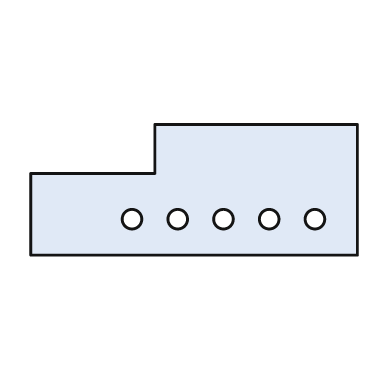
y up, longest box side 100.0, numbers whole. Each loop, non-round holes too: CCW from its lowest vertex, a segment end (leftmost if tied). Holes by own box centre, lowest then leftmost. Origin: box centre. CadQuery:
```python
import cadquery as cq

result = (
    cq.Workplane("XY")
    .moveTo(-50.0, -20.0)
    .lineTo(50.0, -20.0)
    .lineTo(50.0, 20.0)
    .lineTo(-12.0, 20.0)
    .lineTo(-12.0, 5.0)
    .lineTo(-50.0, 5.0)
    .close()
    .moveTo(-19.0, -9.0)
    .circle(3.0)
    .moveTo(-5.0, -9.0)
    .circle(3.0)
    .moveTo(9.0, -9.0)
    .circle(3.0)
    .moveTo(23.0, -9.0)
    .circle(3.0)
    .moveTo(37.0, -9.0)
    .circle(3.0)
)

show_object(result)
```